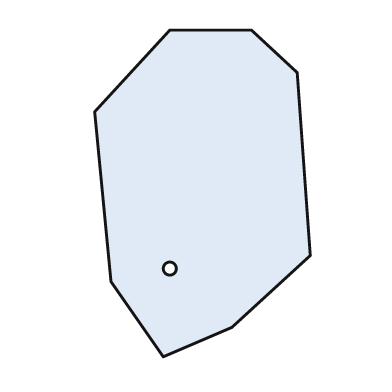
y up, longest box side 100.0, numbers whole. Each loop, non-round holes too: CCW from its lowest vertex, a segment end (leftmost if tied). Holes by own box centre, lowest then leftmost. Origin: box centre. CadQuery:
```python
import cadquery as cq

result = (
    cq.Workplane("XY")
    .moveTo(-12.0, -50.0)
    .lineTo(9.0, -41.0)
    .lineTo(33.0, -19.0)
    .lineTo(29.0, 37.0)
    .lineTo(15.0, 50.0)
    .lineTo(-10.0, 50.0)
    .lineTo(-33.0, 25.0)
    .lineTo(-28.0, -27.0)
    .close()
    .moveTo(-10.0, -23.0)
    .circle(2.0)
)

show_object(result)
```